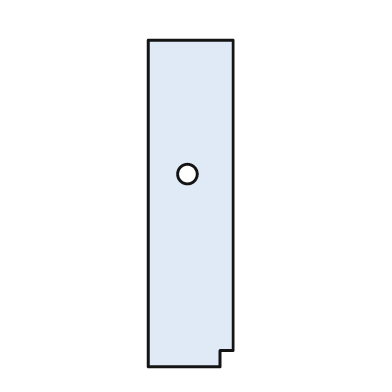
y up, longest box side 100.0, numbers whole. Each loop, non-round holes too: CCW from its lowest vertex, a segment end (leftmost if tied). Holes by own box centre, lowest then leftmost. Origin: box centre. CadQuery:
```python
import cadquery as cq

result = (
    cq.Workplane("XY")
    .moveTo(-13.0, -50.0)
    .lineTo(9.0, -50.0)
    .lineTo(9.0, -45.0)
    .lineTo(13.0, -45.0)
    .lineTo(13.0, 50.0)
    .lineTo(-13.0, 50.0)
    .close()
    .moveTo(-1.0, 9.0)
    .circle(3.0)
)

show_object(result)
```